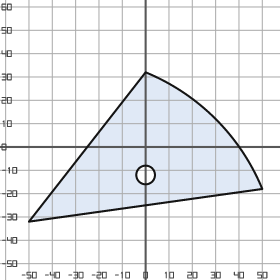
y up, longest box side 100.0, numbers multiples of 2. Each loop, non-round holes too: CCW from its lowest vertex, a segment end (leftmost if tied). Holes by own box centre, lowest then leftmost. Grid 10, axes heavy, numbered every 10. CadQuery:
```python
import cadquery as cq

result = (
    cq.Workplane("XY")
    .moveTo(-50.0, -32.0)
    .lineTo(50.0, -18.0)
    .threePointArc((30.0, 12.0), (0.0, 32.0))
    .close()
    .moveTo(0.0, -12.0)
    .circle(4.0)
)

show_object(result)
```